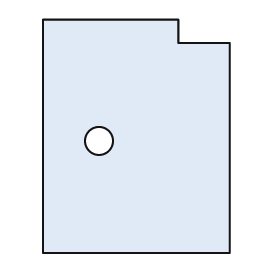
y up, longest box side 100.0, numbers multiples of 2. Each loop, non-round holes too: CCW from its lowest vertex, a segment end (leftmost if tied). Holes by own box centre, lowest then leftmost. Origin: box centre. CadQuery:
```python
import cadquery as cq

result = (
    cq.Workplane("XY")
    .moveTo(-40.0, -50.0)
    .lineTo(40.0, -50.0)
    .lineTo(40.0, 40.0)
    .lineTo(18.0, 40.0)
    .lineTo(18.0, 50.0)
    .lineTo(-40.0, 50.0)
    .close()
    .moveTo(-16.0, -2.0)
    .circle(6.0)
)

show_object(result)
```